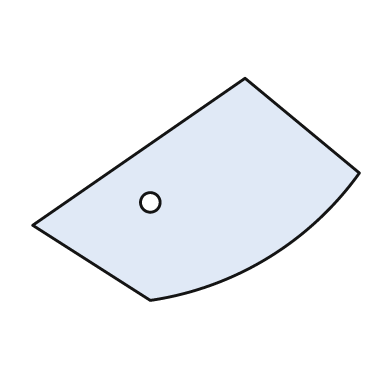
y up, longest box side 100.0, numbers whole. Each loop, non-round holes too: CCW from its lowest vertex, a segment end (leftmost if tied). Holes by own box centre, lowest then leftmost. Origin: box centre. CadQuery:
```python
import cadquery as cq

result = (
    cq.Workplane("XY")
    .moveTo(-14.0, -34.0)
    .threePointArc((22.0, -21.0), (50.0, 5.0))
    .lineTo(15.0, 34.0)
    .lineTo(-50.0, -11.0)
    .close()
    .moveTo(-14.0, -4.0)
    .circle(3.0)
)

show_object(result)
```